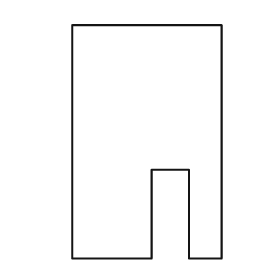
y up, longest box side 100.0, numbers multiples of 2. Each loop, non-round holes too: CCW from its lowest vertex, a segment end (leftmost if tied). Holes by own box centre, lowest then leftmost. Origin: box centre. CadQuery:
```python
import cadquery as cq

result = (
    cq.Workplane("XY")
    .moveTo(-32.0, -50.0)
    .lineTo(2.0, -50.0)
    .lineTo(2.0, -12.0)
    .lineTo(18.0, -12.0)
    .lineTo(18.0, -50.0)
    .lineTo(32.0, -50.0)
    .lineTo(32.0, 50.0)
    .lineTo(-32.0, 50.0)
    .close()
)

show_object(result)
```